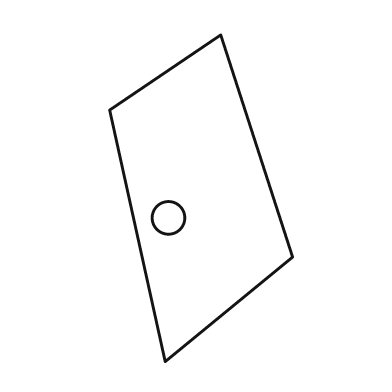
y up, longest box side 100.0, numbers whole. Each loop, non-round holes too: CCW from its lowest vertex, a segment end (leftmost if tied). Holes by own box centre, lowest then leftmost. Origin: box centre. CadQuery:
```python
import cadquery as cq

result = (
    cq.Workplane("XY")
    .moveTo(-11.0, -50.0)
    .lineTo(28.0, -18.0)
    .lineTo(6.0, 50.0)
    .lineTo(-28.0, 27.0)
    .close()
    .moveTo(-10.0, -6.0)
    .circle(5.0)
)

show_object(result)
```